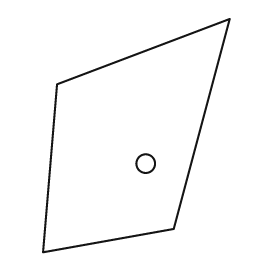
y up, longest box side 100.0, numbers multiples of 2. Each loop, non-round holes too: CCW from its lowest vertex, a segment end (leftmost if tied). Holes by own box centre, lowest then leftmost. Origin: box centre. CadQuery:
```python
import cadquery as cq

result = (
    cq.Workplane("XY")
    .moveTo(-40.0, -50.0)
    .lineTo(16.0, -40.0)
    .lineTo(40.0, 50.0)
    .lineTo(-34.0, 22.0)
    .close()
    .moveTo(4.0, -12.0)
    .circle(4.0)
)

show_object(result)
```